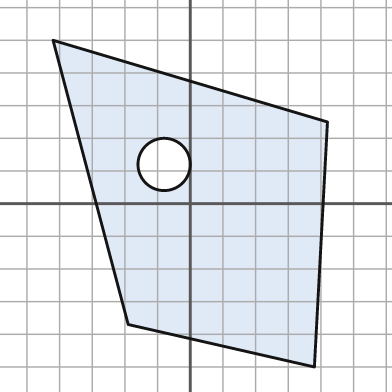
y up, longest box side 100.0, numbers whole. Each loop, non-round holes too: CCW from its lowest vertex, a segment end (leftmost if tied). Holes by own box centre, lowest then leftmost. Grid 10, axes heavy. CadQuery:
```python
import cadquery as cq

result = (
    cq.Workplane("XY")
    .moveTo(38.0, -50.0)
    .lineTo(42.0, 25.0)
    .lineTo(-42.0, 50.0)
    .lineTo(-19.0, -37.0)
    .close()
    .moveTo(-8.0, 12.0)
    .circle(8.0)
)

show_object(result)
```